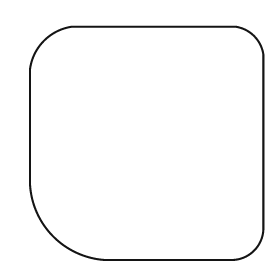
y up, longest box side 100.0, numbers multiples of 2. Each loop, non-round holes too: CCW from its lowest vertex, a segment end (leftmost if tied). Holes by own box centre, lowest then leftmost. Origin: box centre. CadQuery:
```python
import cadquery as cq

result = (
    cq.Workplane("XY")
    .moveTo(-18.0, -50.0)
    .lineTo(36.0, -50.0)
    .threePointArc((46.0, -46.0), (50.0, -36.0))
    .lineTo(50.0, 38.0)
    .threePointArc((46.0, 46.0), (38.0, 50.0))
    .lineTo(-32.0, 50.0)
    .threePointArc((-44.0, 44.0), (-50.0, 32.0))
    .lineTo(-50.0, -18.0)
    .threePointArc((-40.0, -40.0), (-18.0, -50.0))
    .close()
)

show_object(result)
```